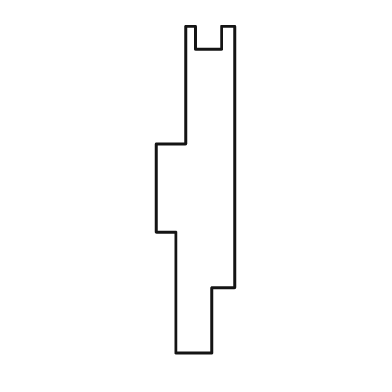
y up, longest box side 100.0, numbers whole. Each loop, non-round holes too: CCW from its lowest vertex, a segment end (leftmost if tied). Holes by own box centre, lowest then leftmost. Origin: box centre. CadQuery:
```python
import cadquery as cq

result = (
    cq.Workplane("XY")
    .moveTo(-6.0, -50.0)
    .lineTo(5.0, -50.0)
    .lineTo(5.0, -30.0)
    .lineTo(12.0, -30.0)
    .lineTo(12.0, 50.0)
    .lineTo(8.0, 50.0)
    .lineTo(8.0, 43.0)
    .lineTo(0.0, 43.0)
    .lineTo(0.0, 50.0)
    .lineTo(-3.0, 50.0)
    .lineTo(-3.0, 14.0)
    .lineTo(-12.0, 14.0)
    .lineTo(-12.0, -13.0)
    .lineTo(-6.0, -13.0)
    .close()
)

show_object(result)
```